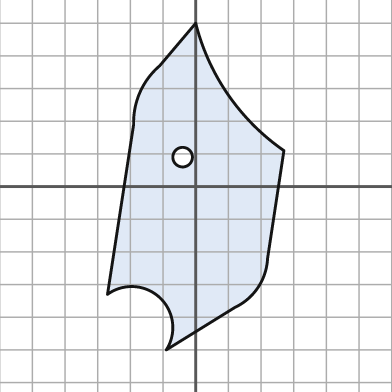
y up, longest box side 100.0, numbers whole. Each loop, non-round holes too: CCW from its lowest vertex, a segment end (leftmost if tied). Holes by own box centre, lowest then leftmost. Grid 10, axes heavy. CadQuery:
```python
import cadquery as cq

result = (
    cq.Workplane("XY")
    .moveTo(-9.0, -50.0)
    .lineTo(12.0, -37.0)
    .threePointArc((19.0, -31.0), (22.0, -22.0))
    .lineTo(27.0, 11.0)
    .threePointArc((10.0, 28.0), (0.0, 50.0))
    .lineTo(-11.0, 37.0)
    .threePointArc((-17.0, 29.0), (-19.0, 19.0))
    .lineTo(-27.0, -33.0)
    .threePointArc((-11.0, -34.0), (-9.0, -50.0))
    .close()
    .moveTo(-4.0, 9.0)
    .circle(3.0)
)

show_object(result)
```